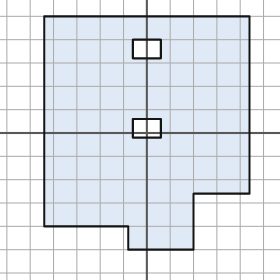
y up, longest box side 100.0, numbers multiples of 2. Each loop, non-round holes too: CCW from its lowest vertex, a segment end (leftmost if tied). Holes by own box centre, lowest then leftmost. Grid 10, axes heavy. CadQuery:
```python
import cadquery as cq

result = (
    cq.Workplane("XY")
    .moveTo(-8.0, -50.0)
    .lineTo(20.0, -50.0)
    .lineTo(20.0, -26.0)
    .lineTo(44.0, -26.0)
    .lineTo(44.0, 50.0)
    .lineTo(-44.0, 50.0)
    .lineTo(-44.0, -40.0)
    .lineTo(-8.0, -40.0)
    .close()
    .moveTo(-6.0, -2.0)
    .lineTo(6.0, -2.0)
    .lineTo(6.0, 6.0)
    .lineTo(-6.0, 6.0)
    .close()
    .moveTo(-6.0, 32.0)
    .lineTo(6.0, 32.0)
    .lineTo(6.0, 40.0)
    .lineTo(-6.0, 40.0)
    .close()
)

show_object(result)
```